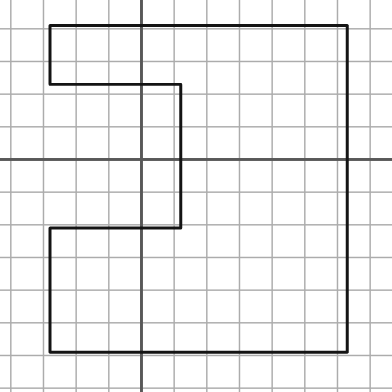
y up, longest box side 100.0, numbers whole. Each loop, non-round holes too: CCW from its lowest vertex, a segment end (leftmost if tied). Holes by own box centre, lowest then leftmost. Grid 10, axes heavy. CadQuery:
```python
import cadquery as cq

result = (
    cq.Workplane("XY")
    .moveTo(-28.0, -59.0)
    .lineTo(63.0, -59.0)
    .lineTo(63.0, 41.0)
    .lineTo(-28.0, 41.0)
    .lineTo(-28.0, 23.0)
    .lineTo(12.0, 23.0)
    .lineTo(12.0, -21.0)
    .lineTo(-28.0, -21.0)
    .close()
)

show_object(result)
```